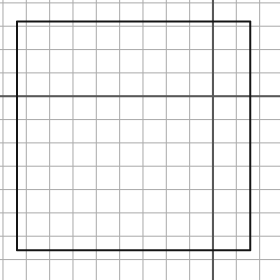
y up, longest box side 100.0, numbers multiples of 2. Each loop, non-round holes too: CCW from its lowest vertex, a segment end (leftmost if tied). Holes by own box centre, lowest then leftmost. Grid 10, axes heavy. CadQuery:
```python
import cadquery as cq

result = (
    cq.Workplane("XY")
    .moveTo(-84.0, -66.0)
    .lineTo(16.0, -66.0)
    .lineTo(16.0, 32.0)
    .lineTo(-84.0, 32.0)
    .close()
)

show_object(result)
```